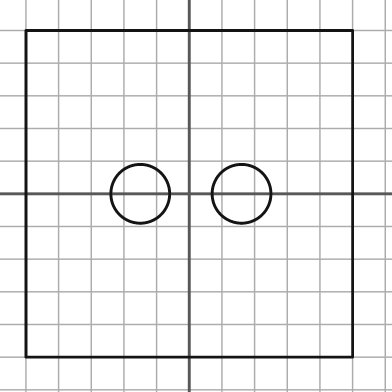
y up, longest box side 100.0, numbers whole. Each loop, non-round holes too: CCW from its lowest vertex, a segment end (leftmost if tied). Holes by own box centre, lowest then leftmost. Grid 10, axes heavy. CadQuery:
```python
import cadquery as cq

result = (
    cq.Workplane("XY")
    .moveTo(-50.0, -50.0)
    .lineTo(50.0, -50.0)
    .lineTo(50.0, 50.0)
    .lineTo(-50.0, 50.0)
    .close()
    .moveTo(-15.0, 0.0)
    .circle(9.0)
    .moveTo(16.0, 0.0)
    .circle(9.0)
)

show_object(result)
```